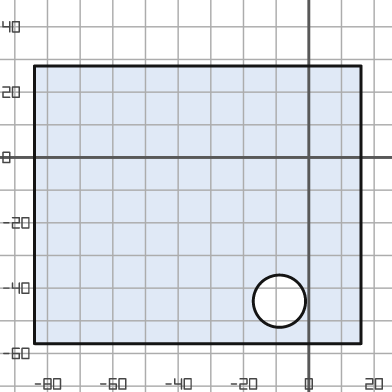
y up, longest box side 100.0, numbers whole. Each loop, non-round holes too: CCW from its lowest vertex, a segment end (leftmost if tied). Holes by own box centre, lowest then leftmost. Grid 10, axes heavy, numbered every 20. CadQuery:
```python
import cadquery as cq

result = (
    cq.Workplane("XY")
    .moveTo(-84.0, -57.0)
    .lineTo(16.0, -57.0)
    .lineTo(16.0, 28.0)
    .lineTo(-84.0, 28.0)
    .close()
    .moveTo(-9.0, -44.0)
    .circle(8.0)
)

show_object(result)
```